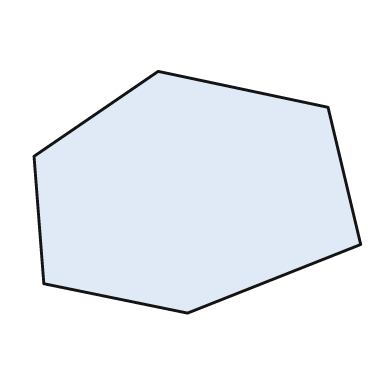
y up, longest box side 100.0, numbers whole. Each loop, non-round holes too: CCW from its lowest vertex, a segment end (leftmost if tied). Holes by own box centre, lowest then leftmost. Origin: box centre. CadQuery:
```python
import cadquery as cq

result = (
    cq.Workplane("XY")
    .moveTo(-3.0, -37.0)
    .lineTo(50.0, -16.0)
    .lineTo(40.0, 26.0)
    .lineTo(-12.0, 37.0)
    .lineTo(-50.0, 11.0)
    .lineTo(-47.0, -28.0)
    .close()
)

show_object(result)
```